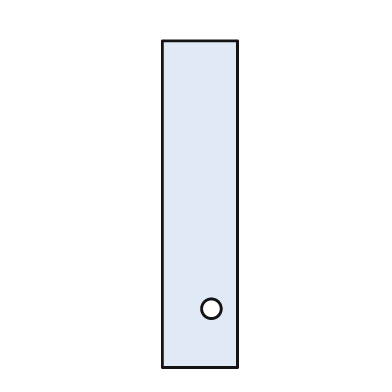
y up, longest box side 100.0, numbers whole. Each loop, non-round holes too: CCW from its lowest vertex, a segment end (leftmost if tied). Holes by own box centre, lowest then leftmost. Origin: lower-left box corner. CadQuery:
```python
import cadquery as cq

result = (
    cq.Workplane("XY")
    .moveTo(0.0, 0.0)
    .lineTo(23.0, 0.0)
    .lineTo(23.0, 100.0)
    .lineTo(0.0, 100.0)
    .close()
    .moveTo(15.0, 18.0)
    .circle(3.0)
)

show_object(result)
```